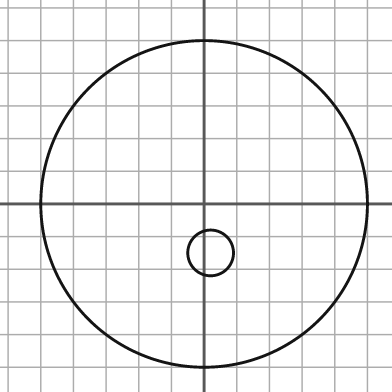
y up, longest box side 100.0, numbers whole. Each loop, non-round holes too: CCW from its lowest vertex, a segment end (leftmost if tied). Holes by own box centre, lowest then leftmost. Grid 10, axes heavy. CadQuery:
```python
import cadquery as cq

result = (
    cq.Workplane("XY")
    .moveTo(0.0, 0.0)
    .circle(50.0)
    .moveTo(2.0, -15.0)
    .circle(7.0)
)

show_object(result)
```